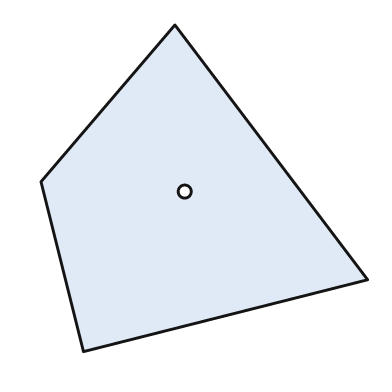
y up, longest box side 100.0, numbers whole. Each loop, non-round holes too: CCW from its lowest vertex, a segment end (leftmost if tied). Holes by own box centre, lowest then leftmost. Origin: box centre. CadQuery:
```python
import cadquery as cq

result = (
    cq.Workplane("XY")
    .moveTo(-37.0, -50.0)
    .lineTo(50.0, -28.0)
    .lineTo(-9.0, 50.0)
    .lineTo(-50.0, 2.0)
    .close()
    .moveTo(-6.0, -1.0)
    .circle(2.0)
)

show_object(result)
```